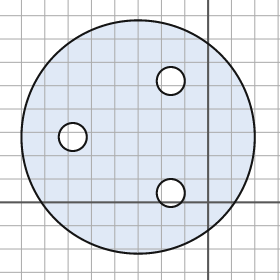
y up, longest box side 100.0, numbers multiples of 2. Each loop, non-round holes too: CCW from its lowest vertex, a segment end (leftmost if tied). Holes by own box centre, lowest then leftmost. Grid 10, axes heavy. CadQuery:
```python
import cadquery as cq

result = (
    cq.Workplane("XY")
    .moveTo(-30.0, 28.0)
    .circle(50.0)
    .moveTo(-16.0, 4.0)
    .circle(6.0)
    .moveTo(-58.0, 28.0)
    .circle(6.0)
    .moveTo(-16.0, 52.0)
    .circle(6.0)
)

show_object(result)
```